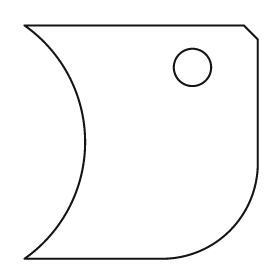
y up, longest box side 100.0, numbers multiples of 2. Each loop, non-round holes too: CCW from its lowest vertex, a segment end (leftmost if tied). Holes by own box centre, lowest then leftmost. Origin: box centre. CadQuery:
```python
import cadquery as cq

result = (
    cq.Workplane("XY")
    .moveTo(-50.0, -50.0)
    .lineTo(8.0, -50.0)
    .threePointArc((38.0, -38.0), (50.0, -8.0))
    .lineTo(50.0, 44.0)
    .lineTo(44.0, 50.0)
    .lineTo(-50.0, 50.0)
    .threePointArc((-24.0, 0.0), (-50.0, -50.0))
    .close()
    .moveTo(22.0, 32.0)
    .circle(8.0)
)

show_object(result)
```